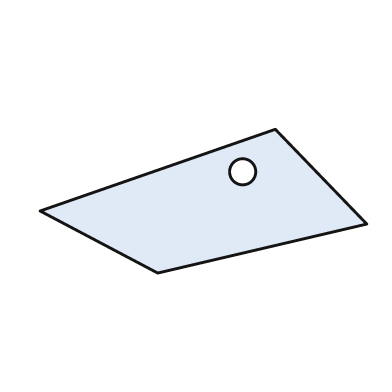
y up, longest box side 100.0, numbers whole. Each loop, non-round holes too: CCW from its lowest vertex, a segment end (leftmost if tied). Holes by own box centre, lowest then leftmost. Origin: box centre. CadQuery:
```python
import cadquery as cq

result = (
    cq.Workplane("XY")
    .moveTo(-14.0, -22.0)
    .lineTo(50.0, -7.0)
    .lineTo(22.0, 22.0)
    .lineTo(-50.0, -3.0)
    .close()
    .moveTo(12.0, 9.0)
    .circle(4.0)
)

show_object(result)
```